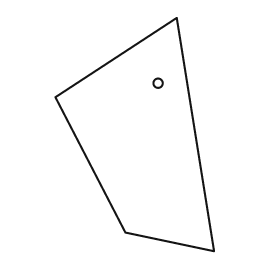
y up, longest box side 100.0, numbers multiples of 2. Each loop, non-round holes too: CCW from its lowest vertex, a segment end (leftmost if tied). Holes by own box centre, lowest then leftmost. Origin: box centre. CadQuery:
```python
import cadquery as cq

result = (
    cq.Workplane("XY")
    .moveTo(34.0, -50.0)
    .lineTo(18.0, 50.0)
    .lineTo(-34.0, 16.0)
    .lineTo(-4.0, -42.0)
    .close()
    .moveTo(10.0, 22.0)
    .circle(2.0)
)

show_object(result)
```